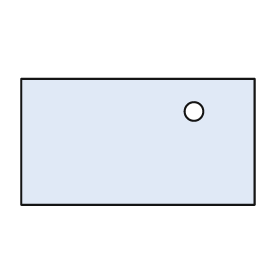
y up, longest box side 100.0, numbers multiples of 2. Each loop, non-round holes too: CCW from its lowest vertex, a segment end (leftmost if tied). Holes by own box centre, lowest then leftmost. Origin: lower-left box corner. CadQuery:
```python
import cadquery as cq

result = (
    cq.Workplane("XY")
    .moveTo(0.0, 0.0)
    .lineTo(100.0, 0.0)
    .lineTo(100.0, 54.0)
    .lineTo(0.0, 54.0)
    .close()
    .moveTo(74.0, 40.0)
    .circle(4.0)
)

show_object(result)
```